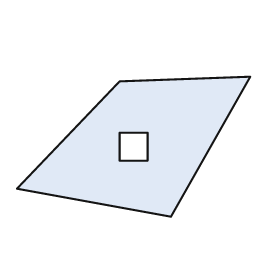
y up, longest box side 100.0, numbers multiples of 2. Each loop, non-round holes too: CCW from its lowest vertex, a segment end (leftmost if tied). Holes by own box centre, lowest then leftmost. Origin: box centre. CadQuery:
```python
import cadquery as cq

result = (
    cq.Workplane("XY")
    .moveTo(16.0, -30.0)
    .lineTo(50.0, 30.0)
    .lineTo(-6.0, 28.0)
    .lineTo(-50.0, -18.0)
    .close()
    .moveTo(-6.0, -6.0)
    .lineTo(6.0, -6.0)
    .lineTo(6.0, 6.0)
    .lineTo(-6.0, 6.0)
    .close()
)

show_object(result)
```